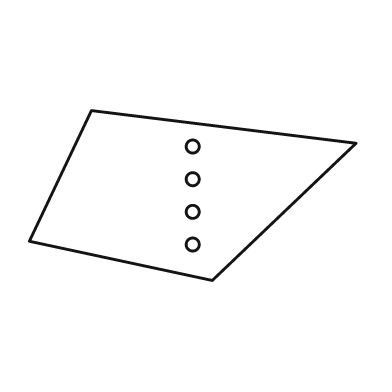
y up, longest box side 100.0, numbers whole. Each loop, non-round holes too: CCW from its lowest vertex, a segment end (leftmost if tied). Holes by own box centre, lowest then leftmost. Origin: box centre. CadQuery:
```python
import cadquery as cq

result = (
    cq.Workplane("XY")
    .moveTo(6.0, -26.0)
    .lineTo(50.0, 16.0)
    .lineTo(-31.0, 26.0)
    .lineTo(-50.0, -14.0)
    .close()
    .moveTo(0.0, -15.0)
    .circle(2.0)
    .moveTo(0.0, -5.0)
    .circle(2.0)
    .moveTo(0.0, 5.0)
    .circle(2.0)
    .moveTo(0.0, 15.0)
    .circle(2.0)
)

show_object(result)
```